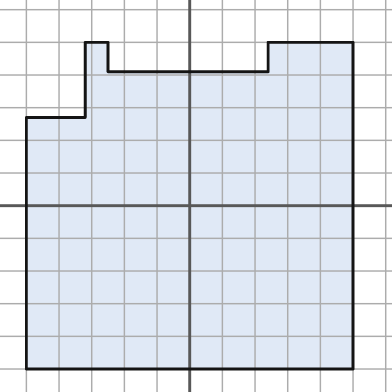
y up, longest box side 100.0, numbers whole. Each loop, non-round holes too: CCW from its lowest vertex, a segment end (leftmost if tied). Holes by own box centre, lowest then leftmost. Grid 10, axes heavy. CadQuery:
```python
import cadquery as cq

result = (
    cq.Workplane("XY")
    .moveTo(-50.0, -50.0)
    .lineTo(50.0, -50.0)
    .lineTo(50.0, 50.0)
    .lineTo(24.0, 50.0)
    .lineTo(24.0, 41.0)
    .lineTo(-25.0, 41.0)
    .lineTo(-25.0, 50.0)
    .lineTo(-32.0, 50.0)
    .lineTo(-32.0, 27.0)
    .lineTo(-50.0, 27.0)
    .close()
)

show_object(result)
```